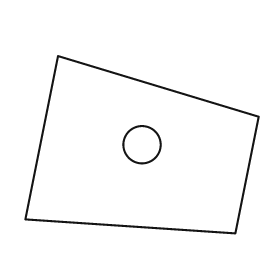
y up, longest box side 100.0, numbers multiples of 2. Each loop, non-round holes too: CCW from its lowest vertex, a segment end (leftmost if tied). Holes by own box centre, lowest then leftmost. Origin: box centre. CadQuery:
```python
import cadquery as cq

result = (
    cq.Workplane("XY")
    .moveTo(40.0, -38.0)
    .lineTo(50.0, 12.0)
    .lineTo(-36.0, 38.0)
    .lineTo(-50.0, -32.0)
    .close()
    .moveTo(0.0, 0.0)
    .circle(8.0)
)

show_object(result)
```